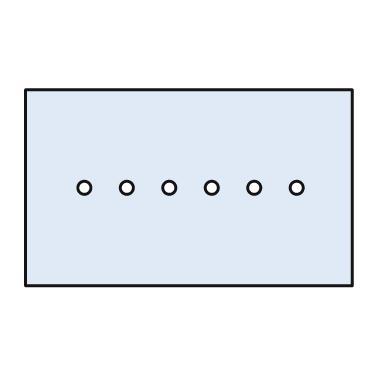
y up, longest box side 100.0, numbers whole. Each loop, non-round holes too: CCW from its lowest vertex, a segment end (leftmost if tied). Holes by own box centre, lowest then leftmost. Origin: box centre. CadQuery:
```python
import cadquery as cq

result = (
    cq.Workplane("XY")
    .moveTo(-50.0, -30.0)
    .lineTo(50.0, -30.0)
    .lineTo(50.0, 30.0)
    .lineTo(-50.0, 30.0)
    .close()
    .moveTo(-32.0, 0.0)
    .circle(2.0)
    .moveTo(-19.0, 0.0)
    .circle(2.0)
    .moveTo(-6.0, 0.0)
    .circle(2.0)
    .moveTo(7.0, 0.0)
    .circle(2.0)
    .moveTo(20.0, 0.0)
    .circle(2.0)
    .moveTo(33.0, 0.0)
    .circle(2.0)
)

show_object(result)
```